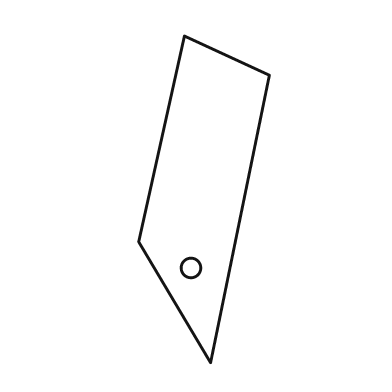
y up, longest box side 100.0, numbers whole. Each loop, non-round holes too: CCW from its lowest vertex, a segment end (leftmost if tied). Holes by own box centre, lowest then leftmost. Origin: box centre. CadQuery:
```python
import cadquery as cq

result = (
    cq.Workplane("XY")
    .moveTo(2.0, -50.0)
    .lineTo(20.0, 38.0)
    .lineTo(-6.0, 50.0)
    .lineTo(-20.0, -13.0)
    .close()
    .moveTo(-4.0, -21.0)
    .circle(3.0)
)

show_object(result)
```